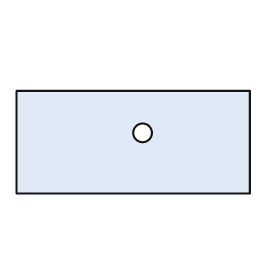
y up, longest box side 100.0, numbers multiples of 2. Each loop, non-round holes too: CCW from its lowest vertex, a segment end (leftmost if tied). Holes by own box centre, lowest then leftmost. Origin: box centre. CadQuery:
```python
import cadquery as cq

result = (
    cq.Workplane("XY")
    .moveTo(-50.0, -22.0)
    .lineTo(50.0, -22.0)
    .lineTo(50.0, 22.0)
    .lineTo(-50.0, 22.0)
    .close()
    .moveTo(4.0, 4.0)
    .circle(4.0)
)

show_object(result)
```